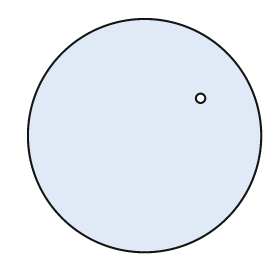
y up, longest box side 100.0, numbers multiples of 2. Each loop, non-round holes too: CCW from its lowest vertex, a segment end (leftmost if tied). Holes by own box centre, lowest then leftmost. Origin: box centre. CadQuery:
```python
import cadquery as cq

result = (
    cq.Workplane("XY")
    .moveTo(0.0, 0.0)
    .circle(50.0)
    .moveTo(24.0, 16.0)
    .circle(2.0)
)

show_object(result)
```